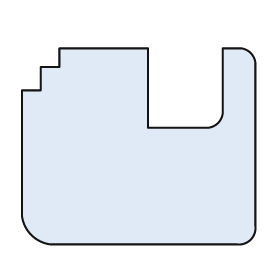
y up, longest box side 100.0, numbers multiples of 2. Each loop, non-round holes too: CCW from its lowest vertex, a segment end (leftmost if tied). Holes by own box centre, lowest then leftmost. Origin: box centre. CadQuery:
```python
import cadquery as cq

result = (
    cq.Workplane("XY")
    .moveTo(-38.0, -42.0)
    .lineTo(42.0, -42.0)
    .threePointArc((48.0, -40.0), (50.0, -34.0))
    .lineTo(50.0, 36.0)
    .threePointArc((48.0, 40.0), (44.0, 42.0))
    .lineTo(36.0, 42.0)
    .lineTo(36.0, 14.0)
    .threePointArc((34.0, 10.0), (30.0, 8.0))
    .lineTo(4.0, 8.0)
    .lineTo(4.0, 42.0)
    .lineTo(-34.0, 42.0)
    .lineTo(-34.0, 34.0)
    .lineTo(-42.0, 34.0)
    .lineTo(-42.0, 24.0)
    .lineTo(-50.0, 24.0)
    .lineTo(-50.0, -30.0)
    .threePointArc((-46.0, -38.0), (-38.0, -42.0))
    .close()
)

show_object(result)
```